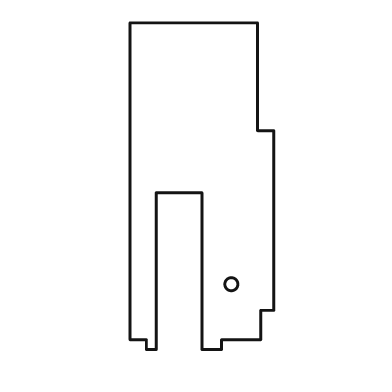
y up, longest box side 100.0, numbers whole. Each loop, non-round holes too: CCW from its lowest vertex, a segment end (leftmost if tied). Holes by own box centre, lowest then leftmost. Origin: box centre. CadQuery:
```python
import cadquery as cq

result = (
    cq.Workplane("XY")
    .moveTo(-17.0, -50.0)
    .lineTo(-14.0, -50.0)
    .lineTo(-14.0, -2.0)
    .lineTo(0.0, -2.0)
    .lineTo(0.0, -50.0)
    .lineTo(6.0, -50.0)
    .lineTo(6.0, -47.0)
    .lineTo(18.0, -47.0)
    .lineTo(18.0, -38.0)
    .lineTo(22.0, -38.0)
    .lineTo(22.0, 17.0)
    .lineTo(17.0, 17.0)
    .lineTo(17.0, 50.0)
    .lineTo(-22.0, 50.0)
    .lineTo(-22.0, -47.0)
    .lineTo(-17.0, -47.0)
    .close()
    .moveTo(9.0, -30.0)
    .circle(2.0)
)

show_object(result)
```